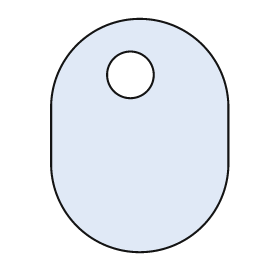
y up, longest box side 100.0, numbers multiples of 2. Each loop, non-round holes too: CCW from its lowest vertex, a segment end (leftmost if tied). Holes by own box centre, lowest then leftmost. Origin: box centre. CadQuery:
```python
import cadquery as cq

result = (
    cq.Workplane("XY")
    .moveTo(-38.0, -12.0)
    .threePointArc((0.0, -50.0), (38.0, -12.0))
    .lineTo(38.0, 12.0)
    .threePointArc((0.0, 50.0), (-38.0, 12.0))
    .close()
    .moveTo(-4.0, 26.0)
    .circle(10.0)
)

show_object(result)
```